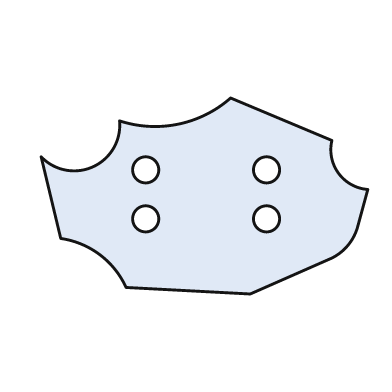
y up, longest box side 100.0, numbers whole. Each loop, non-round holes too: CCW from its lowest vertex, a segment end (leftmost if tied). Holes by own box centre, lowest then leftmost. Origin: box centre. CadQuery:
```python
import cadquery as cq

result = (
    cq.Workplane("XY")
    .moveTo(14.0, -30.0)
    .lineTo(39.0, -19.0)
    .threePointArc((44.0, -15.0), (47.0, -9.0))
    .lineTo(50.0, 2.0)
    .threePointArc((41.0, 7.0), (39.0, 17.0))
    .lineTo(8.0, 30.0)
    .threePointArc((-8.0, 22.0), (-26.0, 23.0))
    .threePointArc((-34.0, 9.0), (-50.0, 12.0))
    .lineTo(-44.0, -13.0)
    .threePointArc((-32.0, -18.0), (-24.0, -28.0))
    .close()
    .moveTo(-18.0, -7.0)
    .circle(4.0)
    .moveTo(19.0, -7.0)
    .circle(4.0)
    .moveTo(-18.0, 8.0)
    .circle(4.0)
    .moveTo(19.0, 8.0)
    .circle(4.0)
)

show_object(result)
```